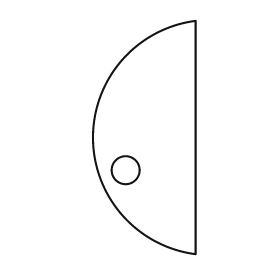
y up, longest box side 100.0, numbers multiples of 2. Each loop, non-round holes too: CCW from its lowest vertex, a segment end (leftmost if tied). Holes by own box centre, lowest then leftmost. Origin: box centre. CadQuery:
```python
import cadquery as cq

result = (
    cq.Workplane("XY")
    .moveTo(22.0, -50.0)
    .lineTo(22.0, 50.0)
    .threePointArc((-22.0, 0.0), (22.0, -50.0))
    .close()
    .moveTo(-8.0, -14.0)
    .circle(6.0)
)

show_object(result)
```